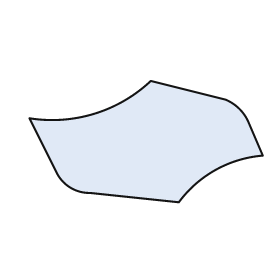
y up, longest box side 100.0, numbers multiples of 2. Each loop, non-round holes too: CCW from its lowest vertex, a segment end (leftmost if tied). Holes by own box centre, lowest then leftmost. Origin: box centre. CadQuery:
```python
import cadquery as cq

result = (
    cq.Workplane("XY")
    .moveTo(14.0, -26.0)
    .threePointArc((30.0, -12.0), (50.0, -6.0))
    .lineTo(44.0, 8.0)
    .threePointArc((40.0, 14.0), (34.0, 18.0))
    .lineTo(2.0, 26.0)
    .threePointArc((-22.0, 12.0), (-50.0, 10.0))
    .lineTo(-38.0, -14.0)
    .threePointArc((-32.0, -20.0), (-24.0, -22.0))
    .close()
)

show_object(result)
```